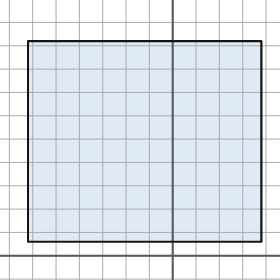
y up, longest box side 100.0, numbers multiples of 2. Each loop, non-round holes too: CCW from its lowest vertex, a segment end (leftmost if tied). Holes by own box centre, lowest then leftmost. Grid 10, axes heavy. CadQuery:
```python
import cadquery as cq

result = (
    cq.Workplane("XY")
    .moveTo(-62.0, 6.0)
    .lineTo(38.0, 6.0)
    .lineTo(38.0, 92.0)
    .lineTo(-62.0, 92.0)
    .close()
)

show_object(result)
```